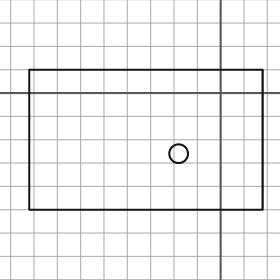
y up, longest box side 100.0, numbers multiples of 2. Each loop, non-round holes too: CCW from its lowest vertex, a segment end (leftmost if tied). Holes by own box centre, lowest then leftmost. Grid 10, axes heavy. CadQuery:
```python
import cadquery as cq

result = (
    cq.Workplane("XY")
    .moveTo(-82.0, -50.0)
    .lineTo(18.0, -50.0)
    .lineTo(18.0, 10.0)
    .lineTo(-82.0, 10.0)
    .close()
    .moveTo(-18.0, -26.0)
    .circle(4.0)
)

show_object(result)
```